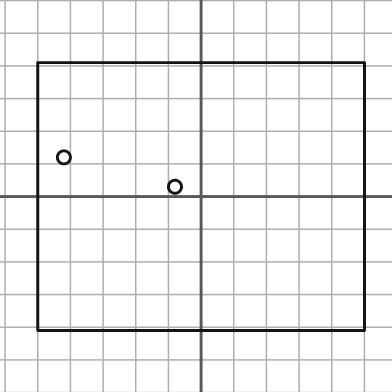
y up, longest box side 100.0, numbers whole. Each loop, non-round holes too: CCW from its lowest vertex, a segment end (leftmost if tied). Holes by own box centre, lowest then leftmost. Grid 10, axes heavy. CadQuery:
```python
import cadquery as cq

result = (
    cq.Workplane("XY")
    .moveTo(-50.0, -41.0)
    .lineTo(50.0, -41.0)
    .lineTo(50.0, 41.0)
    .lineTo(-50.0, 41.0)
    .close()
    .moveTo(-8.0, 3.0)
    .circle(2.0)
    .moveTo(-42.0, 12.0)
    .circle(2.0)
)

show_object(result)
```